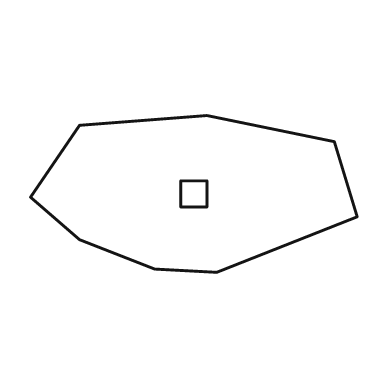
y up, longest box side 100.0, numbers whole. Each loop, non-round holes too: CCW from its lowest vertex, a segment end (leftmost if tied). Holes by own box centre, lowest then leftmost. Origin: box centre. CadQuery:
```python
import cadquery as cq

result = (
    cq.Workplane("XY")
    .moveTo(7.0, -24.0)
    .lineTo(50.0, -7.0)
    .lineTo(43.0, 16.0)
    .lineTo(4.0, 24.0)
    .lineTo(-35.0, 21.0)
    .lineTo(-50.0, -1.0)
    .lineTo(-35.0, -14.0)
    .lineTo(-12.0, -23.0)
    .close()
    .moveTo(-4.0, -4.0)
    .lineTo(4.0, -4.0)
    .lineTo(4.0, 4.0)
    .lineTo(-4.0, 4.0)
    .close()
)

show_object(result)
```